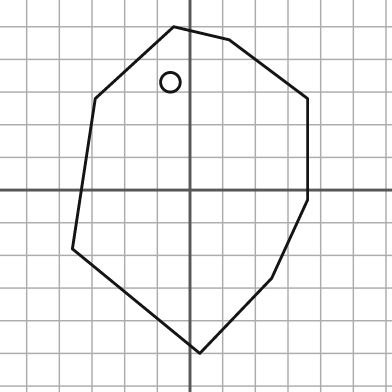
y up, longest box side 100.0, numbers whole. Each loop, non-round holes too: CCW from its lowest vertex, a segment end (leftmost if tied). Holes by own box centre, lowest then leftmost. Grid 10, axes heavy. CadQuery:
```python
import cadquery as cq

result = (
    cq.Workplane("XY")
    .moveTo(3.0, -50.0)
    .lineTo(25.0, -27.0)
    .lineTo(36.0, -3.0)
    .lineTo(36.0, 28.0)
    .lineTo(12.0, 46.0)
    .lineTo(-5.0, 50.0)
    .lineTo(-29.0, 28.0)
    .lineTo(-36.0, -18.0)
    .close()
    .moveTo(-6.0, 33.0)
    .circle(3.0)
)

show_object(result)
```